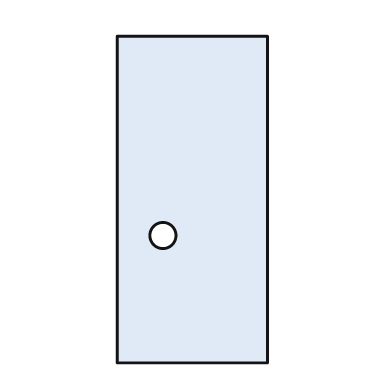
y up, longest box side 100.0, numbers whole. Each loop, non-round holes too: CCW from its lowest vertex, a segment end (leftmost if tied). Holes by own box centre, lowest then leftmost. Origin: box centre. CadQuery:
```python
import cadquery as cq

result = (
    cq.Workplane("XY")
    .moveTo(-23.0, -50.0)
    .lineTo(23.0, -50.0)
    .lineTo(23.0, 50.0)
    .lineTo(-23.0, 50.0)
    .close()
    .moveTo(-9.0, -11.0)
    .circle(4.0)
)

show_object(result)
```